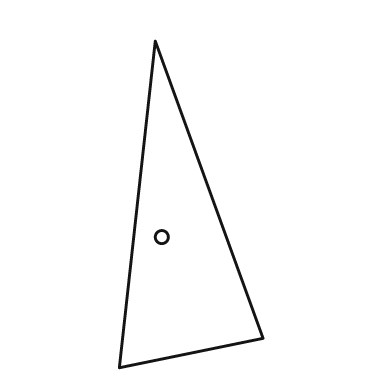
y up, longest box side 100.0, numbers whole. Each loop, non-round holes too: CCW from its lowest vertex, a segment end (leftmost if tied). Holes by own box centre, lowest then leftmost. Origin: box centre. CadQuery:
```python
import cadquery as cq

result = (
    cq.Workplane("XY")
    .moveTo(-22.0, -50.0)
    .lineTo(22.0, -41.0)
    .lineTo(-11.0, 50.0)
    .close()
    .moveTo(-9.0, -10.0)
    .circle(2.0)
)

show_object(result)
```